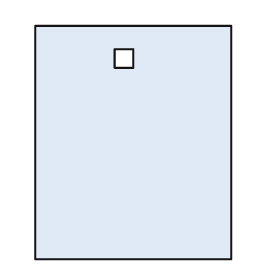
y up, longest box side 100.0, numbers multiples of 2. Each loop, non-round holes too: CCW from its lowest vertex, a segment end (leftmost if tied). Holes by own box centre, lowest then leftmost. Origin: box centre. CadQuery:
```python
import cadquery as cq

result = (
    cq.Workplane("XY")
    .moveTo(-42.0, -50.0)
    .lineTo(42.0, -50.0)
    .lineTo(42.0, 50.0)
    .lineTo(-42.0, 50.0)
    .close()
    .moveTo(-8.0, 32.0)
    .lineTo(0.0, 32.0)
    .lineTo(0.0, 40.0)
    .lineTo(-8.0, 40.0)
    .close()
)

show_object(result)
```